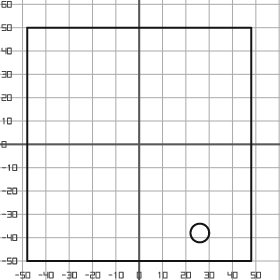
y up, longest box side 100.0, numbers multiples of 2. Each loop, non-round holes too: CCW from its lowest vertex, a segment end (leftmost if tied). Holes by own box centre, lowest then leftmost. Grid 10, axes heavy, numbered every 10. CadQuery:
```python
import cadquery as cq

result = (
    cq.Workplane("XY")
    .moveTo(-48.0, -50.0)
    .lineTo(48.0, -50.0)
    .lineTo(48.0, 50.0)
    .lineTo(-48.0, 50.0)
    .close()
    .moveTo(26.0, -38.0)
    .circle(4.0)
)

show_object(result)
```